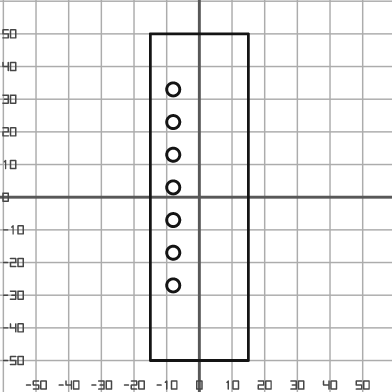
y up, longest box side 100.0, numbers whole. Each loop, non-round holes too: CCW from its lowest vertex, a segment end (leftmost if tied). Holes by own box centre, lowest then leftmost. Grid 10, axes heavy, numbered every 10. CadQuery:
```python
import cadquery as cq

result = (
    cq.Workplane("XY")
    .moveTo(-15.0, -50.0)
    .lineTo(15.0, -50.0)
    .lineTo(15.0, 50.0)
    .lineTo(-15.0, 50.0)
    .close()
    .moveTo(-8.0, -27.0)
    .circle(2.0)
    .moveTo(-8.0, -17.0)
    .circle(2.0)
    .moveTo(-8.0, -7.0)
    .circle(2.0)
    .moveTo(-8.0, 3.0)
    .circle(2.0)
    .moveTo(-8.0, 13.0)
    .circle(2.0)
    .moveTo(-8.0, 23.0)
    .circle(2.0)
    .moveTo(-8.0, 33.0)
    .circle(2.0)
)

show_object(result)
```